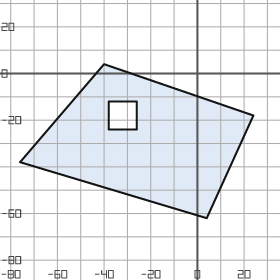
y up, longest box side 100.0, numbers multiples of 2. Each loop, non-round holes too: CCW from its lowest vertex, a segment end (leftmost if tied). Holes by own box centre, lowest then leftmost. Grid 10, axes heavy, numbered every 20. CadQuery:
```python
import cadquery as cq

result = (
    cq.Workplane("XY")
    .moveTo(4.0, -62.0)
    .lineTo(24.0, -18.0)
    .lineTo(-40.0, 4.0)
    .lineTo(-76.0, -38.0)
    .close()
    .moveTo(-38.0, -24.0)
    .lineTo(-26.0, -24.0)
    .lineTo(-26.0, -12.0)
    .lineTo(-38.0, -12.0)
    .close()
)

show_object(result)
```